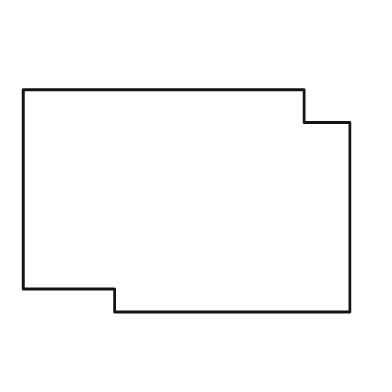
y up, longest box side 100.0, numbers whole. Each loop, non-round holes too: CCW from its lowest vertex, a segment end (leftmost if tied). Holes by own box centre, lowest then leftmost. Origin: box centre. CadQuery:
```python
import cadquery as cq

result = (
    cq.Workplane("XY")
    .moveTo(-22.0, -34.0)
    .lineTo(50.0, -34.0)
    .lineTo(50.0, 24.0)
    .lineTo(36.0, 24.0)
    .lineTo(36.0, 34.0)
    .lineTo(-50.0, 34.0)
    .lineTo(-50.0, -27.0)
    .lineTo(-22.0, -27.0)
    .close()
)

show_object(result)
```